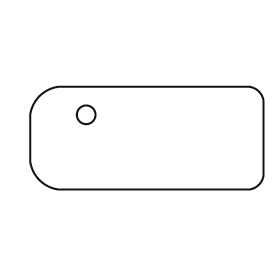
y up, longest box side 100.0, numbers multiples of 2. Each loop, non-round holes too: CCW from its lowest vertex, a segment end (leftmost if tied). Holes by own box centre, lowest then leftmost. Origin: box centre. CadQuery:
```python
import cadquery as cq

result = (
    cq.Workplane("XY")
    .moveTo(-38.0, -22.0)
    .lineTo(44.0, -22.0)
    .threePointArc((48.0, -20.0), (50.0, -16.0))
    .lineTo(50.0, 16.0)
    .threePointArc((48.0, 20.0), (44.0, 22.0))
    .lineTo(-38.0, 22.0)
    .threePointArc((-46.0, 18.0), (-50.0, 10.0))
    .lineTo(-50.0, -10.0)
    .threePointArc((-46.0, -18.0), (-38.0, -22.0))
    .close()
    .moveTo(-26.0, 10.0)
    .circle(4.0)
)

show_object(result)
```